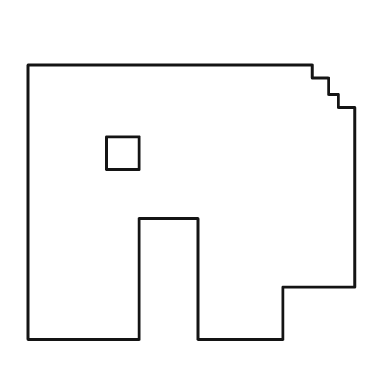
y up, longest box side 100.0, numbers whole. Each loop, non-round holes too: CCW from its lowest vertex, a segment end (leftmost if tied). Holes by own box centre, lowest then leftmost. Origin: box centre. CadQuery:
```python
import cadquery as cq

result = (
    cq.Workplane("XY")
    .moveTo(-50.0, -42.0)
    .lineTo(-16.0, -42.0)
    .lineTo(-16.0, -5.0)
    .lineTo(2.0, -5.0)
    .lineTo(2.0, -42.0)
    .lineTo(28.0, -42.0)
    .lineTo(28.0, -26.0)
    .lineTo(50.0, -26.0)
    .lineTo(50.0, 29.0)
    .lineTo(45.0, 29.0)
    .lineTo(45.0, 33.0)
    .lineTo(42.0, 33.0)
    .lineTo(42.0, 38.0)
    .lineTo(37.0, 38.0)
    .lineTo(37.0, 42.0)
    .lineTo(-50.0, 42.0)
    .close()
    .moveTo(-26.0, 10.0)
    .lineTo(-16.0, 10.0)
    .lineTo(-16.0, 20.0)
    .lineTo(-26.0, 20.0)
    .close()
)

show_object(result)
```